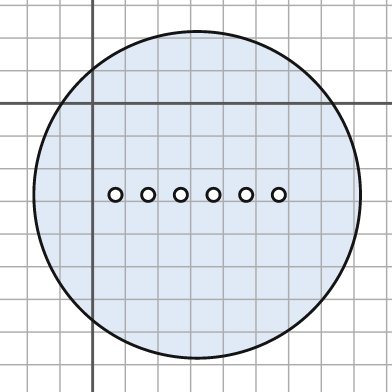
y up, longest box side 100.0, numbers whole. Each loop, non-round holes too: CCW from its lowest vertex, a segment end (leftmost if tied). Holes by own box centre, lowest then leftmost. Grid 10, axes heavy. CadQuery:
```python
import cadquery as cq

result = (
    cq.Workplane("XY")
    .moveTo(32.0, -28.0)
    .circle(50.0)
    .moveTo(7.0, -28.0)
    .circle(2.0)
    .moveTo(17.0, -28.0)
    .circle(2.0)
    .moveTo(27.0, -28.0)
    .circle(2.0)
    .moveTo(37.0, -28.0)
    .circle(2.0)
    .moveTo(47.0, -28.0)
    .circle(2.0)
    .moveTo(57.0, -28.0)
    .circle(2.0)
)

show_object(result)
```